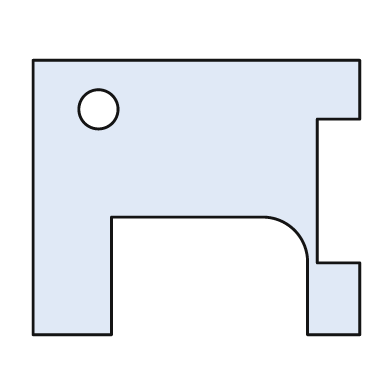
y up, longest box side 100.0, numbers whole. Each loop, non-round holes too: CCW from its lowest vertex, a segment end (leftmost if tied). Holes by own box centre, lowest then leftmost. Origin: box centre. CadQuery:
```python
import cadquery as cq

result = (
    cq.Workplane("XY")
    .moveTo(-50.0, -42.0)
    .lineTo(-26.0, -42.0)
    .lineTo(-26.0, -6.0)
    .lineTo(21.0, -6.0)
    .threePointArc((30.0, -10.0), (34.0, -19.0))
    .lineTo(34.0, -42.0)
    .lineTo(50.0, -42.0)
    .lineTo(50.0, -20.0)
    .lineTo(37.0, -20.0)
    .lineTo(37.0, 24.0)
    .lineTo(50.0, 24.0)
    .lineTo(50.0, 42.0)
    .lineTo(-50.0, 42.0)
    .close()
    .moveTo(-30.0, 27.0)
    .circle(6.0)
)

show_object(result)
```